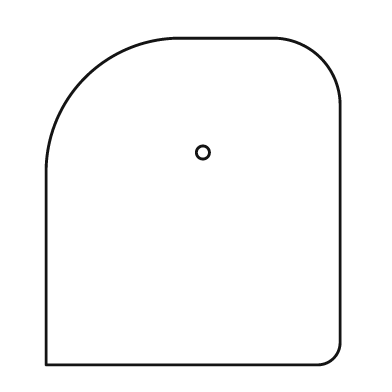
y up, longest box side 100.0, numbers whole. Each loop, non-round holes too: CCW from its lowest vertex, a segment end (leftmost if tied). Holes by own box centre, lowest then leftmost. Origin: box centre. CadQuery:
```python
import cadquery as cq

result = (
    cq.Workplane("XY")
    .moveTo(-45.0, -50.0)
    .lineTo(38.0, -50.0)
    .threePointArc((43.0, -48.0), (45.0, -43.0))
    .lineTo(45.0, 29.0)
    .threePointArc((39.0, 44.0), (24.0, 50.0))
    .lineTo(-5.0, 50.0)
    .threePointArc((-33.0, 38.0), (-45.0, 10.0))
    .close()
    .moveTo(3.0, 15.0)
    .circle(2.0)
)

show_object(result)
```